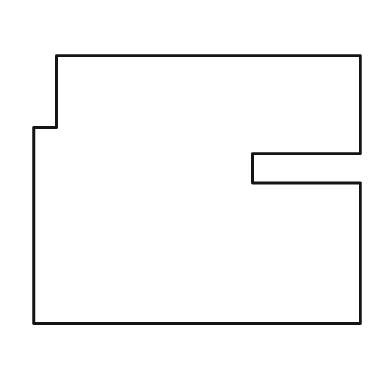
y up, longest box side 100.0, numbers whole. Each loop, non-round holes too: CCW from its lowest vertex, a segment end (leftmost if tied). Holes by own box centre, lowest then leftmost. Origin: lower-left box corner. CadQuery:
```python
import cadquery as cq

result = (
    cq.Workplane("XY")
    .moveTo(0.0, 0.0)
    .lineTo(100.0, 0.0)
    .lineTo(100.0, 43.0)
    .lineTo(67.0, 43.0)
    .lineTo(67.0, 52.0)
    .lineTo(100.0, 52.0)
    .lineTo(100.0, 82.0)
    .lineTo(7.0, 82.0)
    .lineTo(7.0, 60.0)
    .lineTo(0.0, 60.0)
    .close()
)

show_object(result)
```